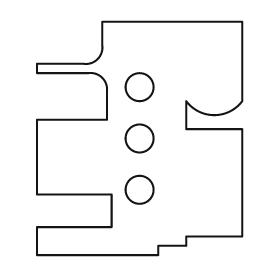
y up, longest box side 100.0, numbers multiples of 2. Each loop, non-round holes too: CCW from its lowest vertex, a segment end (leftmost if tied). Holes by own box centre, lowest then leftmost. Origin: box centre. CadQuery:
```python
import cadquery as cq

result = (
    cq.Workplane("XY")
    .moveTo(-44.0, -50.0)
    .lineTo(8.0, -50.0)
    .lineTo(8.0, -46.0)
    .lineTo(20.0, -46.0)
    .lineTo(20.0, -42.0)
    .lineTo(44.0, -42.0)
    .lineTo(44.0, 4.0)
    .lineTo(20.0, 4.0)
    .lineTo(20.0, 16.0)
    .threePointArc((32.0, 10.0), (44.0, 16.0))
    .lineTo(44.0, 50.0)
    .lineTo(-16.0, 50.0)
    .lineTo(-16.0, 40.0)
    .threePointArc((-18.0, 34.0), (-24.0, 32.0))
    .lineTo(-44.0, 32.0)
    .lineTo(-44.0, 28.0)
    .lineTo(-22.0, 28.0)
    .threePointArc((-16.0, 26.0), (-14.0, 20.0))
    .lineTo(-14.0, 8.0)
    .lineTo(-44.0, 8.0)
    .lineTo(-44.0, -24.0)
    .lineTo(-12.0, -24.0)
    .lineTo(-12.0, -38.0)
    .lineTo(-44.0, -38.0)
    .close()
    .moveTo(0.0, -22.0)
    .circle(6.0)
    .moveTo(0.0, 0.0)
    .circle(6.0)
    .moveTo(0.0, 22.0)
    .circle(6.0)
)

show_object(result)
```